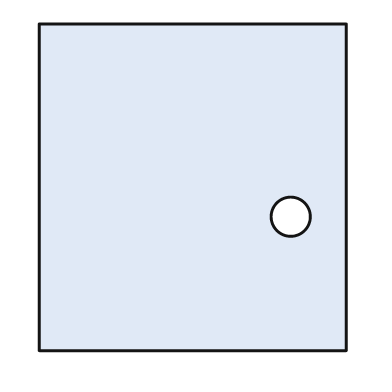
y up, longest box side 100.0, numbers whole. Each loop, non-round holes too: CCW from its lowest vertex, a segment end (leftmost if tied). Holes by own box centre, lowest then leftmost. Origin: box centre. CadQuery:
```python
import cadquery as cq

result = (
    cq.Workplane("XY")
    .moveTo(-47.0, -50.0)
    .lineTo(47.0, -50.0)
    .lineTo(47.0, 50.0)
    .lineTo(-47.0, 50.0)
    .close()
    .moveTo(30.0, -9.0)
    .circle(6.0)
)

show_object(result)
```